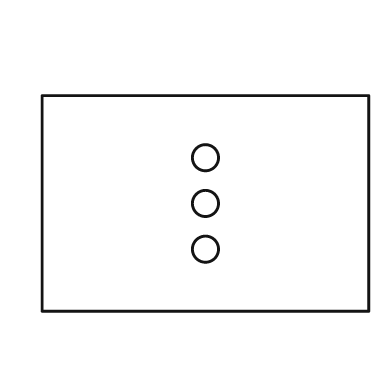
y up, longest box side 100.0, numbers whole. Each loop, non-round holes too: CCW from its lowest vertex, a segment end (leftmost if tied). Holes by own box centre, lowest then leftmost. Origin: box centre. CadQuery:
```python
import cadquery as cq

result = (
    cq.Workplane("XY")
    .moveTo(-50.0, -33.0)
    .lineTo(50.0, -33.0)
    .lineTo(50.0, 33.0)
    .lineTo(-50.0, 33.0)
    .close()
    .moveTo(0.0, -14.0)
    .circle(4.0)
    .moveTo(0.0, 0.0)
    .circle(4.0)
    .moveTo(0.0, 14.0)
    .circle(4.0)
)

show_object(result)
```